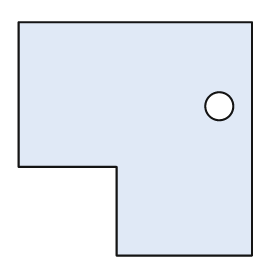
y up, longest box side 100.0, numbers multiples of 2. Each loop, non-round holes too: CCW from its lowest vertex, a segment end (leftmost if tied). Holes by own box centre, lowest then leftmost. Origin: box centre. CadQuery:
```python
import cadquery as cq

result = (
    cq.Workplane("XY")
    .moveTo(-8.0, -50.0)
    .lineTo(50.0, -50.0)
    .lineTo(50.0, 50.0)
    .lineTo(-50.0, 50.0)
    .lineTo(-50.0, -12.0)
    .lineTo(-8.0, -12.0)
    .close()
    .moveTo(36.0, 14.0)
    .circle(6.0)
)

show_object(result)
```